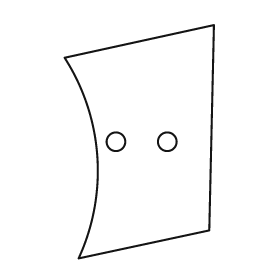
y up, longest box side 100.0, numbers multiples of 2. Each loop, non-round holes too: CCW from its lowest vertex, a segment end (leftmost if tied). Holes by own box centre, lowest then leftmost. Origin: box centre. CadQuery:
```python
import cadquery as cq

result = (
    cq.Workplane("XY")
    .moveTo(-26.0, -50.0)
    .lineTo(30.0, -38.0)
    .lineTo(32.0, 50.0)
    .lineTo(-32.0, 36.0)
    .threePointArc((-18.0, -6.0), (-26.0, -50.0))
    .close()
    .moveTo(-10.0, 0.0)
    .circle(4.0)
    .moveTo(12.0, 0.0)
    .circle(4.0)
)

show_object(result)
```